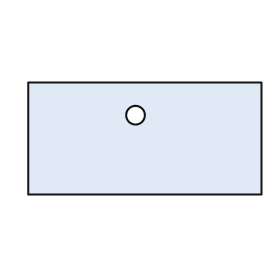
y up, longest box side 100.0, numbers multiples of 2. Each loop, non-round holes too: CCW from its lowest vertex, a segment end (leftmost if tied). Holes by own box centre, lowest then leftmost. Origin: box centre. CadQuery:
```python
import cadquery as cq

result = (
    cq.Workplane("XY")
    .moveTo(-50.0, -24.0)
    .lineTo(50.0, -24.0)
    .lineTo(50.0, 24.0)
    .lineTo(-50.0, 24.0)
    .close()
    .moveTo(-4.0, 10.0)
    .circle(4.0)
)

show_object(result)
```